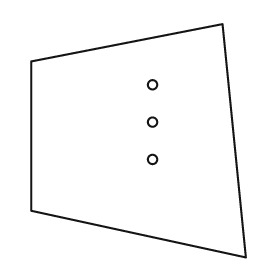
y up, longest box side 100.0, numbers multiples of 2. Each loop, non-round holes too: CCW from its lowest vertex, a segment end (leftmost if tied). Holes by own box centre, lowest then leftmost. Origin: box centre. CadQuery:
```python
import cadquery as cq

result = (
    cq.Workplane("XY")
    .moveTo(46.0, -50.0)
    .lineTo(36.0, 50.0)
    .lineTo(-46.0, 34.0)
    .lineTo(-46.0, -30.0)
    .close()
    .moveTo(6.0, -8.0)
    .circle(2.0)
    .moveTo(6.0, 8.0)
    .circle(2.0)
    .moveTo(6.0, 24.0)
    .circle(2.0)
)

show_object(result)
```